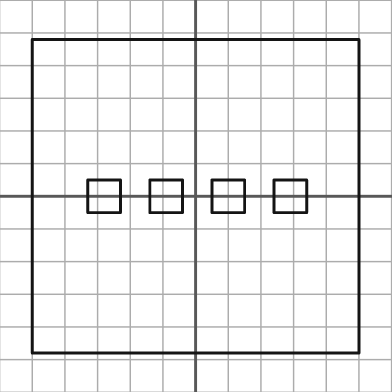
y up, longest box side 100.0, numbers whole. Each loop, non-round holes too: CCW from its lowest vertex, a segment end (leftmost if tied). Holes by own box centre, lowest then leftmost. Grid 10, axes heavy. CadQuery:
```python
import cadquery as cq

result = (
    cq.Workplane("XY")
    .moveTo(-50.0, -48.0)
    .lineTo(50.0, -48.0)
    .lineTo(50.0, 48.0)
    .lineTo(-50.0, 48.0)
    .close()
    .moveTo(-33.0, -5.0)
    .lineTo(-23.0, -5.0)
    .lineTo(-23.0, 5.0)
    .lineTo(-33.0, 5.0)
    .close()
    .moveTo(-14.0, -5.0)
    .lineTo(-4.0, -5.0)
    .lineTo(-4.0, 5.0)
    .lineTo(-14.0, 5.0)
    .close()
    .moveTo(5.0, -5.0)
    .lineTo(15.0, -5.0)
    .lineTo(15.0, 5.0)
    .lineTo(5.0, 5.0)
    .close()
    .moveTo(24.0, -5.0)
    .lineTo(34.0, -5.0)
    .lineTo(34.0, 5.0)
    .lineTo(24.0, 5.0)
    .close()
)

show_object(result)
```